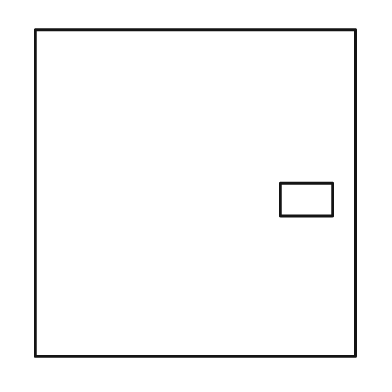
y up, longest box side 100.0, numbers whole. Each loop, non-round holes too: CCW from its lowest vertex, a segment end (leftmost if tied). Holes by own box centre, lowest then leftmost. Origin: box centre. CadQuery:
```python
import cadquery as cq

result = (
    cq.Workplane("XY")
    .moveTo(-49.0, -50.0)
    .lineTo(49.0, -50.0)
    .lineTo(49.0, 50.0)
    .lineTo(-49.0, 50.0)
    .close()
    .moveTo(26.0, -7.0)
    .lineTo(42.0, -7.0)
    .lineTo(42.0, 3.0)
    .lineTo(26.0, 3.0)
    .close()
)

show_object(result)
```